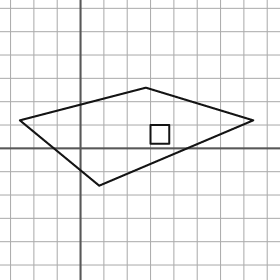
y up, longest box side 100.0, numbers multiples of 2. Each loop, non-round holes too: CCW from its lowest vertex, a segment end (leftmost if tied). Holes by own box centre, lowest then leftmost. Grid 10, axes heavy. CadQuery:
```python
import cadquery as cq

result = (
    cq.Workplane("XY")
    .moveTo(8.0, -16.0)
    .lineTo(74.0, 12.0)
    .lineTo(28.0, 26.0)
    .lineTo(-26.0, 12.0)
    .close()
    .moveTo(30.0, 2.0)
    .lineTo(38.0, 2.0)
    .lineTo(38.0, 10.0)
    .lineTo(30.0, 10.0)
    .close()
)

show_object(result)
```